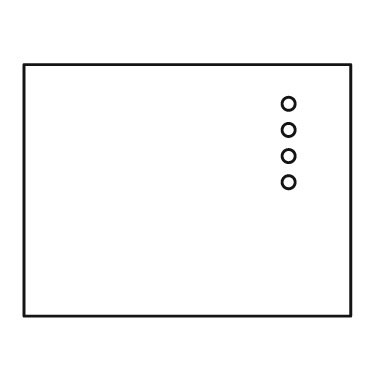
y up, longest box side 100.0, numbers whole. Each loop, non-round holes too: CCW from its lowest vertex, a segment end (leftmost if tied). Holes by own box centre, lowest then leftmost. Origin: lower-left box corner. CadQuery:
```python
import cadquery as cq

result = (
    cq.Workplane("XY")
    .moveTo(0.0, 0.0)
    .lineTo(100.0, 0.0)
    .lineTo(100.0, 77.0)
    .lineTo(0.0, 77.0)
    .close()
    .moveTo(81.0, 41.0)
    .circle(2.0)
    .moveTo(81.0, 49.0)
    .circle(2.0)
    .moveTo(81.0, 57.0)
    .circle(2.0)
    .moveTo(81.0, 65.0)
    .circle(2.0)
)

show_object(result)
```